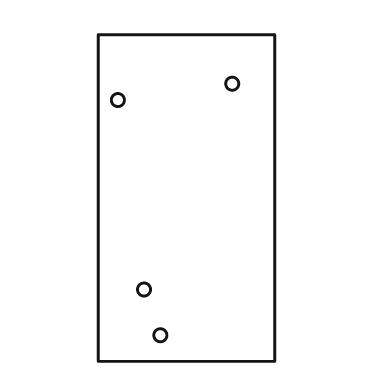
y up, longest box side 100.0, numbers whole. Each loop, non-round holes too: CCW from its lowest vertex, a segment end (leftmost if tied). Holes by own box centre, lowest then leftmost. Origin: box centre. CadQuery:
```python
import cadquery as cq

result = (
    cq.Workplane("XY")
    .moveTo(-27.0, -50.0)
    .lineTo(27.0, -50.0)
    .lineTo(27.0, 50.0)
    .lineTo(-27.0, 50.0)
    .close()
    .moveTo(-8.0, -42.0)
    .circle(2.0)
    .moveTo(-13.0, -28.0)
    .circle(2.0)
    .moveTo(-21.0, 30.0)
    .circle(2.0)
    .moveTo(14.0, 35.0)
    .circle(2.0)
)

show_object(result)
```